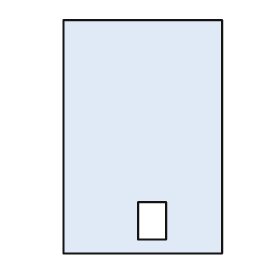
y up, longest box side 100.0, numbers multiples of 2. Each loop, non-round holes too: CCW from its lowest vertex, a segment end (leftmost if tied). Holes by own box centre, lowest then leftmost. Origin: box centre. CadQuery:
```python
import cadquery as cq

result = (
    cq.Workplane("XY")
    .moveTo(-34.0, -50.0)
    .lineTo(34.0, -50.0)
    .lineTo(34.0, 50.0)
    .lineTo(-34.0, 50.0)
    .close()
    .moveTo(-2.0, -44.0)
    .lineTo(10.0, -44.0)
    .lineTo(10.0, -28.0)
    .lineTo(-2.0, -28.0)
    .close()
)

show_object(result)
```